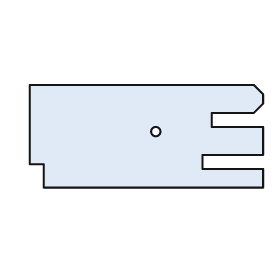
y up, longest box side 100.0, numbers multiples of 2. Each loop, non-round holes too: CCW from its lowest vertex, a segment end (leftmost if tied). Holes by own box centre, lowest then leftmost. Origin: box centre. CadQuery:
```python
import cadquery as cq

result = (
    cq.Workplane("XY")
    .moveTo(-44.0, -22.0)
    .lineTo(50.0, -22.0)
    .lineTo(50.0, -14.0)
    .lineTo(24.0, -14.0)
    .lineTo(24.0, -8.0)
    .lineTo(50.0, -8.0)
    .lineTo(50.0, 4.0)
    .lineTo(28.0, 4.0)
    .lineTo(28.0, 10.0)
    .lineTo(46.0, 10.0)
    .lineTo(50.0, 14.0)
    .lineTo(50.0, 18.0)
    .lineTo(46.0, 22.0)
    .lineTo(-50.0, 22.0)
    .lineTo(-50.0, -12.0)
    .lineTo(-44.0, -12.0)
    .close()
    .moveTo(4.0, 2.0)
    .circle(2.0)
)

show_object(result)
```